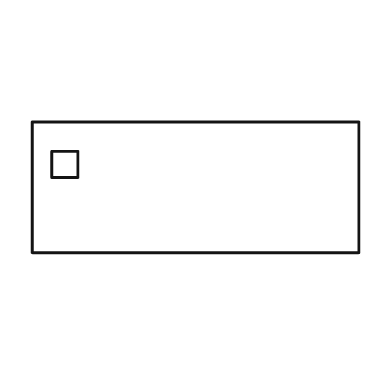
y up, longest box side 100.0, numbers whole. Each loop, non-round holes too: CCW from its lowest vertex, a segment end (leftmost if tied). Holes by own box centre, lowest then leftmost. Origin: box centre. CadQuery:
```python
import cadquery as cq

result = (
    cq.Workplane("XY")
    .moveTo(-50.0, -20.0)
    .lineTo(50.0, -20.0)
    .lineTo(50.0, 20.0)
    .lineTo(-50.0, 20.0)
    .close()
    .moveTo(-44.0, 3.0)
    .lineTo(-36.0, 3.0)
    .lineTo(-36.0, 11.0)
    .lineTo(-44.0, 11.0)
    .close()
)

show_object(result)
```